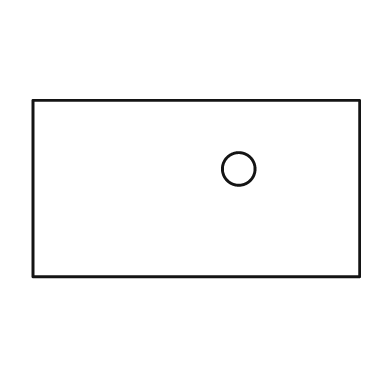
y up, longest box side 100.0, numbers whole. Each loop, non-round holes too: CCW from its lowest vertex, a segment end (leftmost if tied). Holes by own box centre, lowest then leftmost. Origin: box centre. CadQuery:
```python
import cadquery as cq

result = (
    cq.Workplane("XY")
    .moveTo(-50.0, -27.0)
    .lineTo(50.0, -27.0)
    .lineTo(50.0, 27.0)
    .lineTo(-50.0, 27.0)
    .close()
    .moveTo(13.0, 6.0)
    .circle(5.0)
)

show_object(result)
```